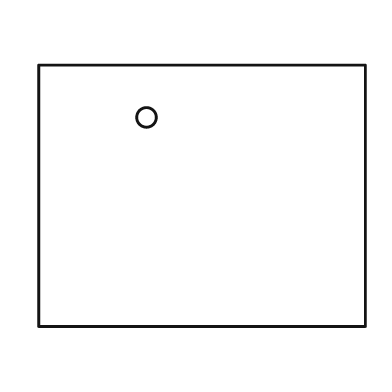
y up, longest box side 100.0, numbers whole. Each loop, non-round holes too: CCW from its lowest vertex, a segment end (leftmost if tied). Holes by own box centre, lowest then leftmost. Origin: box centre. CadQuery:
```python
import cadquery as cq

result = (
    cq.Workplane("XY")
    .moveTo(-50.0, -40.0)
    .lineTo(50.0, -40.0)
    .lineTo(50.0, 40.0)
    .lineTo(-50.0, 40.0)
    .close()
    .moveTo(-17.0, 24.0)
    .circle(3.0)
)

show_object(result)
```